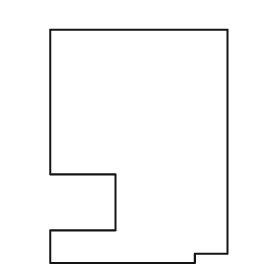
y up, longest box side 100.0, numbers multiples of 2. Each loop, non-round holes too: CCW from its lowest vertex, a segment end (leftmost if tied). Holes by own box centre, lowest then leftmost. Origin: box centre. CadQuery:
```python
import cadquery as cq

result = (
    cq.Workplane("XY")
    .moveTo(-38.0, -50.0)
    .lineTo(24.0, -50.0)
    .lineTo(24.0, -46.0)
    .lineTo(38.0, -46.0)
    .lineTo(38.0, 50.0)
    .lineTo(-38.0, 50.0)
    .lineTo(-38.0, -12.0)
    .lineTo(-10.0, -12.0)
    .lineTo(-10.0, -36.0)
    .lineTo(-38.0, -36.0)
    .close()
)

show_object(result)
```